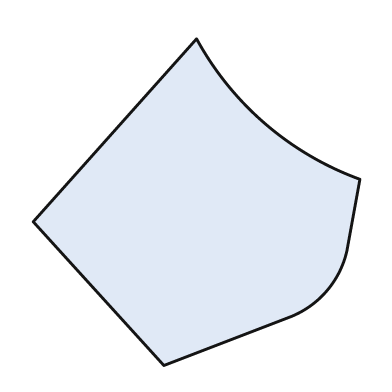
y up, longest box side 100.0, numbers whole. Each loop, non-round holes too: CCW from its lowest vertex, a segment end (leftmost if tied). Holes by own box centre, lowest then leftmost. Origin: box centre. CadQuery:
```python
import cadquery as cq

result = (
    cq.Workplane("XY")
    .moveTo(-10.0, -50.0)
    .lineTo(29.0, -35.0)
    .threePointArc((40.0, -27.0), (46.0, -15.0))
    .lineTo(50.0, 7.0)
    .threePointArc((21.0, 24.0), (0.0, 50.0))
    .lineTo(-50.0, -6.0)
    .close()
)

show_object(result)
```